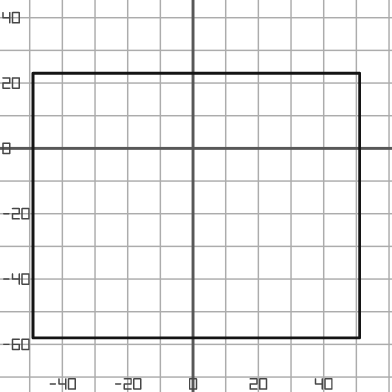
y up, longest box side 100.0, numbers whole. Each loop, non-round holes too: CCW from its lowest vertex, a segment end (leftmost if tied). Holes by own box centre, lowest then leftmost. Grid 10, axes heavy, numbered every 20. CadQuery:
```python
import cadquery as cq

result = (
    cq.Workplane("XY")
    .moveTo(-49.0, -58.0)
    .lineTo(51.0, -58.0)
    .lineTo(51.0, 23.0)
    .lineTo(-49.0, 23.0)
    .close()
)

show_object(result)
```